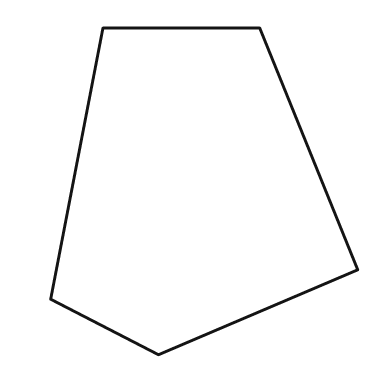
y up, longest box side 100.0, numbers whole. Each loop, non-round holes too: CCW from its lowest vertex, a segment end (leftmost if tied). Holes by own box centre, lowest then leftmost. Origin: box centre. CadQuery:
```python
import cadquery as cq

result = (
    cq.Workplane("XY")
    .moveTo(-14.0, -50.0)
    .lineTo(47.0, -24.0)
    .lineTo(17.0, 50.0)
    .lineTo(-31.0, 50.0)
    .lineTo(-47.0, -33.0)
    .close()
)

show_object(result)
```